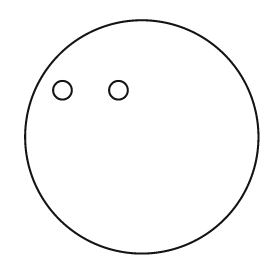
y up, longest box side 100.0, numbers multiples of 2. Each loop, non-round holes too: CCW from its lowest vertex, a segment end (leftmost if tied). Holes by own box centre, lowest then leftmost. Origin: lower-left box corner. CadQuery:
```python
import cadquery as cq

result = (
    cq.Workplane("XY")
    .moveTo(50.0, 50.0)
    .circle(50.0)
    .moveTo(16.0, 70.0)
    .circle(4.0)
    .moveTo(40.0, 70.0)
    .circle(4.0)
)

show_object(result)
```